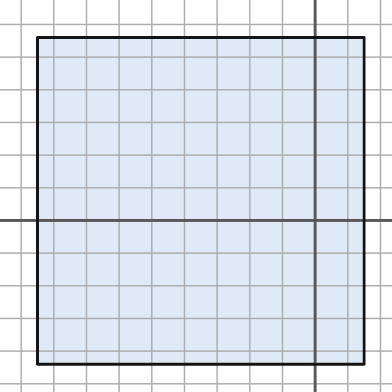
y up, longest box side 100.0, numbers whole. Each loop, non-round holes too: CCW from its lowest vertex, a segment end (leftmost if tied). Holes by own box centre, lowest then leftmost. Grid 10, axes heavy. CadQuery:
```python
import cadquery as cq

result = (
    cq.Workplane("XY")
    .moveTo(-85.0, -44.0)
    .lineTo(15.0, -44.0)
    .lineTo(15.0, 56.0)
    .lineTo(-85.0, 56.0)
    .close()
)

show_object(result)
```